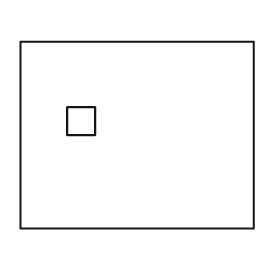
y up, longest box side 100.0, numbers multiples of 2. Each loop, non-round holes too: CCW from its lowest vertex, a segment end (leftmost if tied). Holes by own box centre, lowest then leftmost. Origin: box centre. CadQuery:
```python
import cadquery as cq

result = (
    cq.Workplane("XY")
    .moveTo(-50.0, -40.0)
    .lineTo(50.0, -40.0)
    .lineTo(50.0, 40.0)
    .lineTo(-50.0, 40.0)
    .close()
    .moveTo(-30.0, 0.0)
    .lineTo(-18.0, 0.0)
    .lineTo(-18.0, 12.0)
    .lineTo(-30.0, 12.0)
    .close()
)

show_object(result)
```